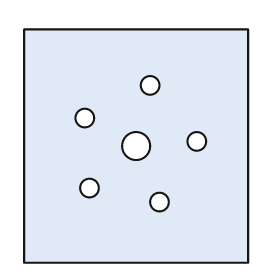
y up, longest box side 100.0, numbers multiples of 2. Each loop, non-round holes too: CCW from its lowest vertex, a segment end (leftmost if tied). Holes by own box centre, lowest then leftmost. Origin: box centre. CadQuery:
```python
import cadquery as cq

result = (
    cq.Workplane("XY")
    .moveTo(-48.0, -50.0)
    .lineTo(48.0, -50.0)
    .lineTo(48.0, 50.0)
    .lineTo(-48.0, 50.0)
    .close()
    .moveTo(10.0, -24.0)
    .circle(4.0)
    .moveTo(-20.0, -18.0)
    .circle(4.0)
    .moveTo(0.0, 0.0)
    .circle(6.0)
    .moveTo(26.0, 2.0)
    .circle(4.0)
    .moveTo(-22.0, 12.0)
    .circle(4.0)
    .moveTo(6.0, 26.0)
    .circle(4.0)
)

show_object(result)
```